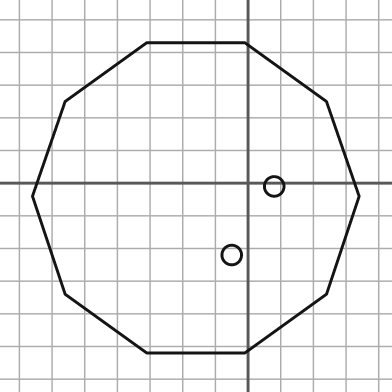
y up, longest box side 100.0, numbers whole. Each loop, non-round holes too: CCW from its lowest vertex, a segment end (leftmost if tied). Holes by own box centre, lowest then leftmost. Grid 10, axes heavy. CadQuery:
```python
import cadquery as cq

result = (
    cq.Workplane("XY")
    .moveTo(-31.0, -52.0)
    .lineTo(-1.0, -52.0)
    .lineTo(24.0, -34.0)
    .lineTo(34.0, -4.0)
    .lineTo(24.0, 25.0)
    .lineTo(-1.0, 43.0)
    .lineTo(-31.0, 43.0)
    .lineTo(-56.0, 25.0)
    .lineTo(-66.0, -4.0)
    .lineTo(-56.0, -34.0)
    .close()
    .moveTo(-5.0, -22.0)
    .circle(3.0)
    .moveTo(8.0, -1.0)
    .circle(3.0)
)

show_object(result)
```